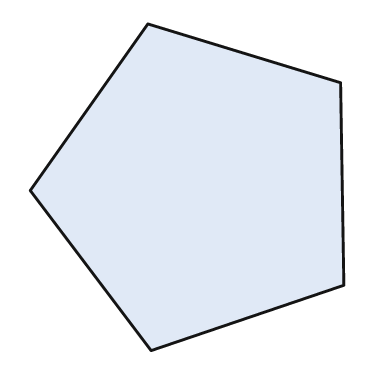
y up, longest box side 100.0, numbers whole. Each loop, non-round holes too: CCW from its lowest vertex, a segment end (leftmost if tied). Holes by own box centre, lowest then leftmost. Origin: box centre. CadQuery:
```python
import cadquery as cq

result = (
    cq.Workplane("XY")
    .moveTo(-11.0, -50.0)
    .lineTo(48.0, -30.0)
    .lineTo(47.0, 32.0)
    .lineTo(-12.0, 50.0)
    .lineTo(-48.0, -1.0)
    .close()
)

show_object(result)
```